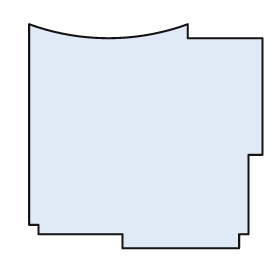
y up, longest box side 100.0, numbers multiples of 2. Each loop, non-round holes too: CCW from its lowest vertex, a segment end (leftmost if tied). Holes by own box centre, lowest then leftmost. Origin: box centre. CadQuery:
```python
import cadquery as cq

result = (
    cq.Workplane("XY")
    .moveTo(-10.0, -48.0)
    .lineTo(40.0, -48.0)
    .lineTo(40.0, -42.0)
    .lineTo(44.0, -42.0)
    .lineTo(44.0, -8.0)
    .lineTo(50.0, -8.0)
    .lineTo(50.0, 42.0)
    .lineTo(18.0, 42.0)
    .lineTo(18.0, 48.0)
    .threePointArc((-16.0, 42.0), (-50.0, 48.0))
    .lineTo(-50.0, -38.0)
    .lineTo(-46.0, -38.0)
    .lineTo(-46.0, -42.0)
    .lineTo(-10.0, -42.0)
    .close()
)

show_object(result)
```